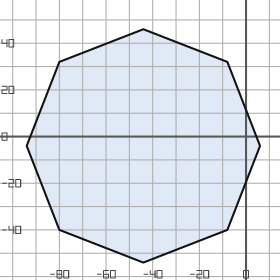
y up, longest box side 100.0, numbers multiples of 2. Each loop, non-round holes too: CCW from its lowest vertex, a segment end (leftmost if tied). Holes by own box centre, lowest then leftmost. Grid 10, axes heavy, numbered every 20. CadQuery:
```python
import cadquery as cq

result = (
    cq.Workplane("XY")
    .moveTo(-44.0, -54.0)
    .lineTo(-8.0, -40.0)
    .lineTo(6.0, -4.0)
    .lineTo(-8.0, 32.0)
    .lineTo(-44.0, 46.0)
    .lineTo(-80.0, 32.0)
    .lineTo(-94.0, -4.0)
    .lineTo(-80.0, -40.0)
    .close()
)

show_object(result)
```